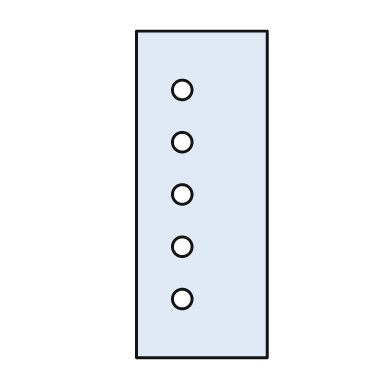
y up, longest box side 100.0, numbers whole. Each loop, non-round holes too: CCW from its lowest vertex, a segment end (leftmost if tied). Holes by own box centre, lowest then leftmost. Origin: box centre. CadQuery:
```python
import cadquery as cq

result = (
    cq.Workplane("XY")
    .moveTo(-20.0, -50.0)
    .lineTo(20.0, -50.0)
    .lineTo(20.0, 50.0)
    .lineTo(-20.0, 50.0)
    .close()
    .moveTo(-6.0, -32.0)
    .circle(3.0)
    .moveTo(-6.0, -16.0)
    .circle(3.0)
    .moveTo(-6.0, 0.0)
    .circle(3.0)
    .moveTo(-6.0, 16.0)
    .circle(3.0)
    .moveTo(-6.0, 32.0)
    .circle(3.0)
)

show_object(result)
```